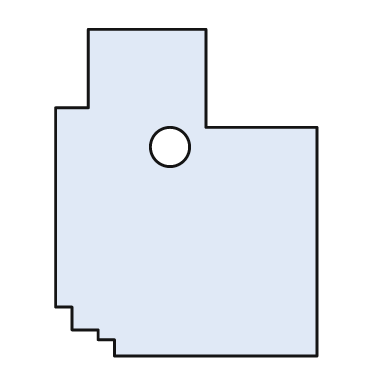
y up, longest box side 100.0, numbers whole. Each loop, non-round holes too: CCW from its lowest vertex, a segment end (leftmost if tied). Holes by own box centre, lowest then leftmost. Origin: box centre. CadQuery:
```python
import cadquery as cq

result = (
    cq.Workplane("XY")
    .moveTo(-22.0, -50.0)
    .lineTo(40.0, -50.0)
    .lineTo(40.0, 20.0)
    .lineTo(6.0, 20.0)
    .lineTo(6.0, 50.0)
    .lineTo(-30.0, 50.0)
    .lineTo(-30.0, 26.0)
    .lineTo(-40.0, 26.0)
    .lineTo(-40.0, -35.0)
    .lineTo(-35.0, -35.0)
    .lineTo(-35.0, -42.0)
    .lineTo(-27.0, -42.0)
    .lineTo(-27.0, -45.0)
    .lineTo(-22.0, -45.0)
    .close()
    .moveTo(-5.0, 14.0)
    .circle(6.0)
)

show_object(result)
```